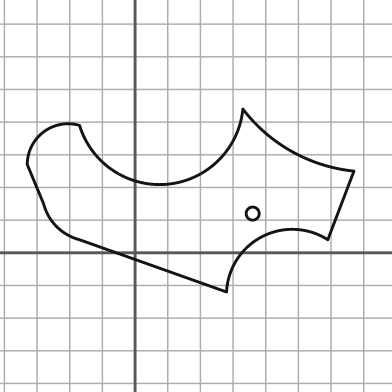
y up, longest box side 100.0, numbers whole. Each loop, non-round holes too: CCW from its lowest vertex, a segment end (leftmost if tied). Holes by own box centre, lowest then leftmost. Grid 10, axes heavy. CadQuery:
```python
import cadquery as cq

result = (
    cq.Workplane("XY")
    .moveTo(28.0, -12.0)
    .threePointArc((39.0, 5.0), (59.0, 4.0))
    .lineTo(67.0, 25.0)
    .threePointArc((48.0, 31.0), (33.0, 44.0))
    .threePointArc((10.0, 21.0), (-17.0, 39.0))
    .threePointArc((-28.0, 37.0), (-33.0, 27.0))
    .lineTo(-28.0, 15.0)
    .threePointArc((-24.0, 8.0), (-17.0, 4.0))
    .close()
    .moveTo(36.0, 12.0)
    .circle(2.0)
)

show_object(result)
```